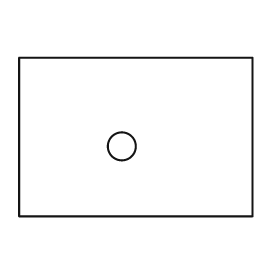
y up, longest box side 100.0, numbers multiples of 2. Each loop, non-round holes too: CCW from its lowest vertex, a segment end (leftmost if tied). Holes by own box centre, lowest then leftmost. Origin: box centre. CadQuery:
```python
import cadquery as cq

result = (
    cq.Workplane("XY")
    .moveTo(-50.0, -34.0)
    .lineTo(50.0, -34.0)
    .lineTo(50.0, 34.0)
    .lineTo(-50.0, 34.0)
    .close()
    .moveTo(-6.0, -4.0)
    .circle(6.0)
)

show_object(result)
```